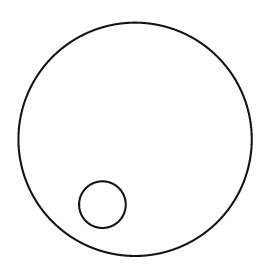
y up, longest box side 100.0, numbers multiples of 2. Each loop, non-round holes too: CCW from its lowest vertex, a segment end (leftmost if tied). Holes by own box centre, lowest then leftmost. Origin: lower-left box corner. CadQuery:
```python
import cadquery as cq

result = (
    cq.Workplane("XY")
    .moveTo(50.0, 50.0)
    .circle(50.0)
    .moveTo(36.0, 22.0)
    .circle(10.0)
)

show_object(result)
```